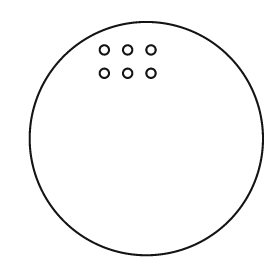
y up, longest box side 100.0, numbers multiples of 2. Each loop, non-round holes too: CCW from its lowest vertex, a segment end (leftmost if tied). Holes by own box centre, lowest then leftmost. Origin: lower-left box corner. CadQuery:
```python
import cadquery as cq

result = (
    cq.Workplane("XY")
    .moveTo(50.0, 50.0)
    .circle(50.0)
    .moveTo(32.0, 78.0)
    .circle(2.0)
    .moveTo(42.0, 78.0)
    .circle(2.0)
    .moveTo(52.0, 78.0)
    .circle(2.0)
    .moveTo(32.0, 88.0)
    .circle(2.0)
    .moveTo(42.0, 88.0)
    .circle(2.0)
    .moveTo(52.0, 88.0)
    .circle(2.0)
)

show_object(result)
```